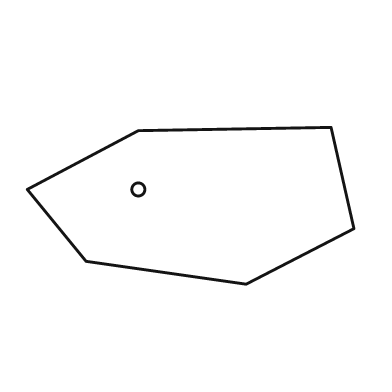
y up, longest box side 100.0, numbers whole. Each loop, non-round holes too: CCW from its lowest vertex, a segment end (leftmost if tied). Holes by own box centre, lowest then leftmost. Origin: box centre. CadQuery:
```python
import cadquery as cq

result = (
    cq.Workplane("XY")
    .moveTo(17.0, -24.0)
    .lineTo(50.0, -7.0)
    .lineTo(43.0, 24.0)
    .lineTo(-16.0, 23.0)
    .lineTo(-50.0, 5.0)
    .lineTo(-32.0, -17.0)
    .close()
    .moveTo(-16.0, 5.0)
    .circle(2.0)
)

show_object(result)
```